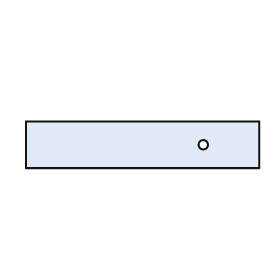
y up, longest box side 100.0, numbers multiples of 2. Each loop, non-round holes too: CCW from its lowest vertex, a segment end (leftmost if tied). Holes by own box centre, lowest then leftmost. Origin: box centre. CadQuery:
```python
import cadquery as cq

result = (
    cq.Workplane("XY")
    .moveTo(-50.0, -10.0)
    .lineTo(50.0, -10.0)
    .lineTo(50.0, 10.0)
    .lineTo(-50.0, 10.0)
    .close()
    .moveTo(26.0, 0.0)
    .circle(2.0)
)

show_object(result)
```